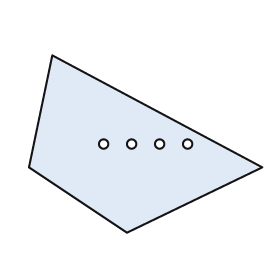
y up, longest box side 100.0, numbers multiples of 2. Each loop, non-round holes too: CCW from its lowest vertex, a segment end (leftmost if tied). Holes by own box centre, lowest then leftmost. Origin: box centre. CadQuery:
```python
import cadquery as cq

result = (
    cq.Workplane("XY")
    .moveTo(-8.0, -38.0)
    .lineTo(50.0, -10.0)
    .lineTo(-40.0, 38.0)
    .lineTo(-50.0, -10.0)
    .close()
    .moveTo(-18.0, 0.0)
    .circle(2.0)
    .moveTo(-6.0, 0.0)
    .circle(2.0)
    .moveTo(6.0, 0.0)
    .circle(2.0)
    .moveTo(18.0, 0.0)
    .circle(2.0)
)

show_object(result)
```